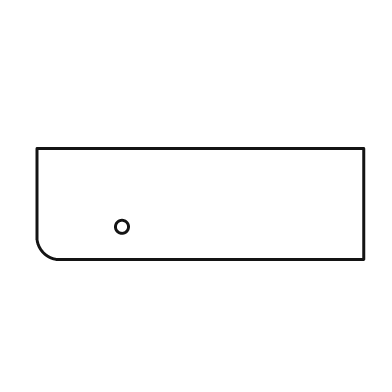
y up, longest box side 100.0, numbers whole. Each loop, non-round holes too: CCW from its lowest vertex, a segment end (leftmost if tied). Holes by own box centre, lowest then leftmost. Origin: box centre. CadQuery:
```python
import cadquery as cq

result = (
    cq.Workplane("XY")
    .moveTo(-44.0, -17.0)
    .lineTo(50.0, -17.0)
    .lineTo(50.0, 17.0)
    .lineTo(-50.0, 17.0)
    .lineTo(-50.0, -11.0)
    .threePointArc((-48.0, -15.0), (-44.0, -17.0))
    .close()
    .moveTo(-24.0, -7.0)
    .circle(2.0)
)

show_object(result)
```